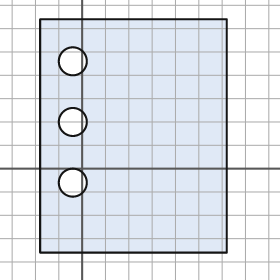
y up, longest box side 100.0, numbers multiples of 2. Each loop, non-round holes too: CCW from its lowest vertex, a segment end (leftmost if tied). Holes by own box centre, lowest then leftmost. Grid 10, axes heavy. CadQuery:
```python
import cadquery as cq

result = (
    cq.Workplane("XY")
    .moveTo(-18.0, -36.0)
    .lineTo(62.0, -36.0)
    .lineTo(62.0, 64.0)
    .lineTo(-18.0, 64.0)
    .close()
    .moveTo(-4.0, -6.0)
    .circle(6.0)
    .moveTo(-4.0, 20.0)
    .circle(6.0)
    .moveTo(-4.0, 46.0)
    .circle(6.0)
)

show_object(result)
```